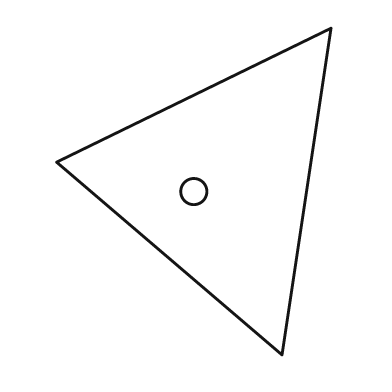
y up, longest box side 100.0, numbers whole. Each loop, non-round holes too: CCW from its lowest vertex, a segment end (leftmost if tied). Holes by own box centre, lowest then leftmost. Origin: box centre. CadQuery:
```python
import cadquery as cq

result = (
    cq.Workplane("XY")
    .moveTo(27.0, -50.0)
    .lineTo(42.0, 50.0)
    .lineTo(-42.0, 9.0)
    .close()
    .moveTo(0.0, 0.0)
    .circle(4.0)
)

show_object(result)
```